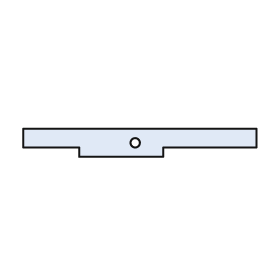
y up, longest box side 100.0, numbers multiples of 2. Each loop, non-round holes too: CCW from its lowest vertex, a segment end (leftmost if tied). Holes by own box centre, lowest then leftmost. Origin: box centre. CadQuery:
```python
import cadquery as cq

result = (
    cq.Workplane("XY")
    .moveTo(-26.0, -6.0)
    .lineTo(10.0, -6.0)
    .lineTo(10.0, -2.0)
    .lineTo(50.0, -2.0)
    .lineTo(50.0, 6.0)
    .lineTo(-50.0, 6.0)
    .lineTo(-50.0, -2.0)
    .lineTo(-26.0, -2.0)
    .close()
    .moveTo(-2.0, 0.0)
    .circle(2.0)
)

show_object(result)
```